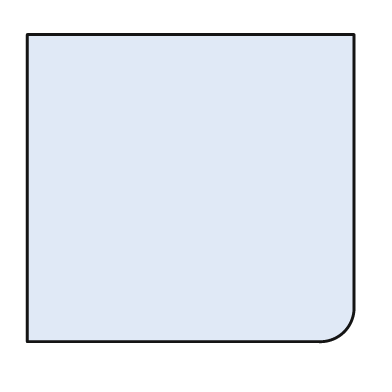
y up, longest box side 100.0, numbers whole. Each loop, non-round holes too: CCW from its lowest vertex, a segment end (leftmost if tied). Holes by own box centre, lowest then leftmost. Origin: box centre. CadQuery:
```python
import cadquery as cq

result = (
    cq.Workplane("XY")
    .moveTo(-50.0, -47.0)
    .lineTo(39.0, -47.0)
    .threePointArc((47.0, -44.0), (50.0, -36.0))
    .lineTo(50.0, 47.0)
    .lineTo(-50.0, 47.0)
    .close()
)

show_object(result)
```